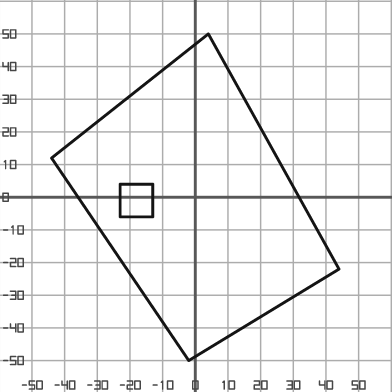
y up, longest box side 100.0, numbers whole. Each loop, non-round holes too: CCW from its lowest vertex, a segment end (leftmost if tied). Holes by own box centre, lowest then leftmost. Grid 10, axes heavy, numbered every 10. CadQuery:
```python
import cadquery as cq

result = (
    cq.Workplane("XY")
    .moveTo(-2.0, -50.0)
    .lineTo(44.0, -22.0)
    .lineTo(4.0, 50.0)
    .lineTo(-44.0, 12.0)
    .close()
    .moveTo(-23.0, -6.0)
    .lineTo(-13.0, -6.0)
    .lineTo(-13.0, 4.0)
    .lineTo(-23.0, 4.0)
    .close()
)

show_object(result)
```